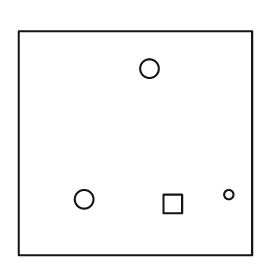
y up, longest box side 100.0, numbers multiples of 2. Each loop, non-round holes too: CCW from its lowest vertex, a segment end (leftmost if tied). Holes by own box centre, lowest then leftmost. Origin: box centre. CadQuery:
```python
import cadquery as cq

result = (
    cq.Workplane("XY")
    .moveTo(-50.0, -48.0)
    .lineTo(50.0, -48.0)
    .lineTo(50.0, 48.0)
    .lineTo(-50.0, 48.0)
    .close()
    .moveTo(12.0, -30.0)
    .lineTo(20.0, -30.0)
    .lineTo(20.0, -22.0)
    .lineTo(12.0, -22.0)
    .close()
    .moveTo(-22.0, -24.0)
    .circle(4.0)
    .moveTo(40.0, -22.0)
    .circle(2.0)
    .moveTo(6.0, 32.0)
    .circle(4.0)
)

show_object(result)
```